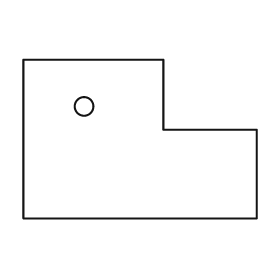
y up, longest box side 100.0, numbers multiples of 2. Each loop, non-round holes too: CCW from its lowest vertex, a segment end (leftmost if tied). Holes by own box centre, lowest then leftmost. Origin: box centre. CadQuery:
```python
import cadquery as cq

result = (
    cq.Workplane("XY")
    .moveTo(-50.0, -34.0)
    .lineTo(50.0, -34.0)
    .lineTo(50.0, 4.0)
    .lineTo(10.0, 4.0)
    .lineTo(10.0, 34.0)
    .lineTo(-50.0, 34.0)
    .close()
    .moveTo(-24.0, 14.0)
    .circle(4.0)
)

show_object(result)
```